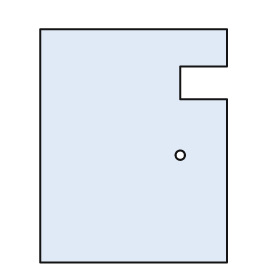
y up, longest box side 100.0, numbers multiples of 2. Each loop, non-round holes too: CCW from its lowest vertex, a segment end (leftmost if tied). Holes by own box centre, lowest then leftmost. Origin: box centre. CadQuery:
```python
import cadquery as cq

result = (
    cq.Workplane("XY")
    .moveTo(-40.0, -50.0)
    .lineTo(40.0, -50.0)
    .lineTo(40.0, 20.0)
    .lineTo(20.0, 20.0)
    .lineTo(20.0, 34.0)
    .lineTo(40.0, 34.0)
    .lineTo(40.0, 50.0)
    .lineTo(-40.0, 50.0)
    .close()
    .moveTo(20.0, -4.0)
    .circle(2.0)
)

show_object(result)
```